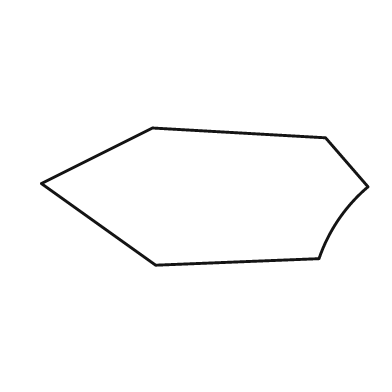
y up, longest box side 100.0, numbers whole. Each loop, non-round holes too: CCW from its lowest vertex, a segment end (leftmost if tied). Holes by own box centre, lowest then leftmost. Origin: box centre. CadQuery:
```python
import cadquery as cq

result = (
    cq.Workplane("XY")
    .moveTo(-15.0, -21.0)
    .lineTo(35.0, -19.0)
    .threePointArc((41.0, -7.0), (50.0, 3.0))
    .lineTo(37.0, 18.0)
    .lineTo(-16.0, 21.0)
    .lineTo(-50.0, 4.0)
    .close()
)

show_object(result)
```